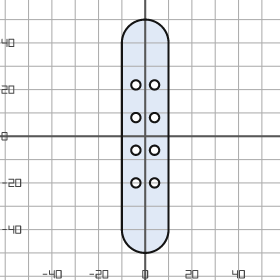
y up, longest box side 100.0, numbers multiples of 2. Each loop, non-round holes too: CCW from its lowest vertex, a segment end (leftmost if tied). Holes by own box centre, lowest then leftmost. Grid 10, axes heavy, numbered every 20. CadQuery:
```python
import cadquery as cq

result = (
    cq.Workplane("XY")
    .moveTo(-10.0, -40.0)
    .threePointArc((0.0, -50.0), (10.0, -40.0))
    .lineTo(10.0, 40.0)
    .threePointArc((0.0, 50.0), (-10.0, 40.0))
    .close()
    .moveTo(-4.0, -20.0)
    .circle(2.0)
    .moveTo(4.0, -20.0)
    .circle(2.0)
    .moveTo(-4.0, -6.0)
    .circle(2.0)
    .moveTo(4.0, -6.0)
    .circle(2.0)
    .moveTo(-4.0, 8.0)
    .circle(2.0)
    .moveTo(4.0, 8.0)
    .circle(2.0)
    .moveTo(-4.0, 22.0)
    .circle(2.0)
    .moveTo(4.0, 22.0)
    .circle(2.0)
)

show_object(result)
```